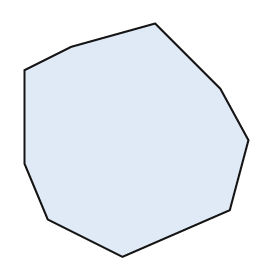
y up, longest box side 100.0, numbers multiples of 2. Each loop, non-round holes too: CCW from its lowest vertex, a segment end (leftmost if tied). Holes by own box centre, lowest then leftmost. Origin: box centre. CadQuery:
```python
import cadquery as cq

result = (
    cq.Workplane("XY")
    .moveTo(-6.0, -50.0)
    .lineTo(40.0, -30.0)
    .lineTo(48.0, 0.0)
    .lineTo(36.0, 22.0)
    .lineTo(8.0, 50.0)
    .lineTo(-28.0, 40.0)
    .lineTo(-48.0, 30.0)
    .lineTo(-48.0, -10.0)
    .lineTo(-38.0, -34.0)
    .close()
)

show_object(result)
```